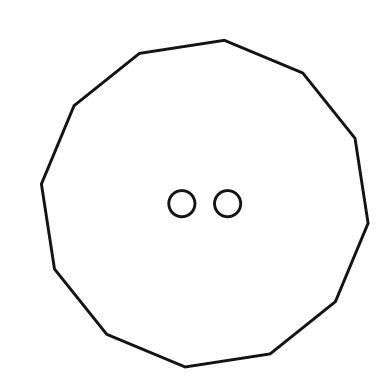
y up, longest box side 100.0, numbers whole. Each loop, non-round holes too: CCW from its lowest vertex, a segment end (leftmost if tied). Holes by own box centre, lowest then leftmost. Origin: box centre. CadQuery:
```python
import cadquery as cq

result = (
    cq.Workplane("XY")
    .moveTo(-6.0, -50.0)
    .lineTo(20.0, -46.0)
    .lineTo(40.0, -30.0)
    .lineTo(50.0, -6.0)
    .lineTo(46.0, 20.0)
    .lineTo(30.0, 40.0)
    .lineTo(6.0, 50.0)
    .lineTo(-20.0, 46.0)
    .lineTo(-40.0, 30.0)
    .lineTo(-50.0, 6.0)
    .lineTo(-46.0, -20.0)
    .lineTo(-30.0, -40.0)
    .close()
    .moveTo(-7.0, 0.0)
    .circle(4.0)
    .moveTo(7.0, 0.0)
    .circle(4.0)
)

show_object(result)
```